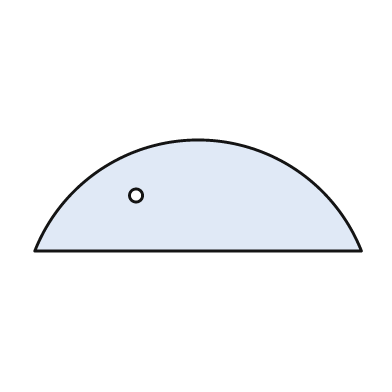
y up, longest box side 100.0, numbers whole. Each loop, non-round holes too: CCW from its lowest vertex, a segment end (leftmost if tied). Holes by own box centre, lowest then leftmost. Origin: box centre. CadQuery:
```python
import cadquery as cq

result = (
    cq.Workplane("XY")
    .moveTo(-50.0, -17.0)
    .lineTo(50.0, -17.0)
    .threePointArc((0.0, 17.0), (-50.0, -17.0))
    .close()
    .moveTo(-19.0, 0.0)
    .circle(2.0)
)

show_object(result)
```